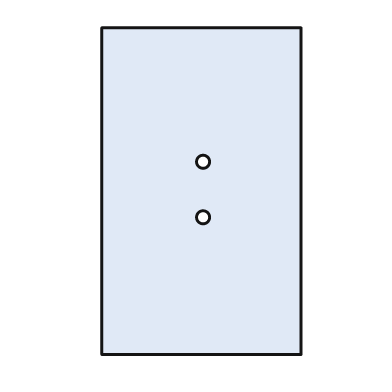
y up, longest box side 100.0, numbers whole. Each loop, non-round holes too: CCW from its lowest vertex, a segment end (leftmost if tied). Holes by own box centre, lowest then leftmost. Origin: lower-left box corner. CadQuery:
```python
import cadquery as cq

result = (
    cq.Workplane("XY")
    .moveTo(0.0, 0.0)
    .lineTo(61.0, 0.0)
    .lineTo(61.0, 100.0)
    .lineTo(0.0, 100.0)
    .close()
    .moveTo(31.0, 42.0)
    .circle(2.0)
    .moveTo(31.0, 59.0)
    .circle(2.0)
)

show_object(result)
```